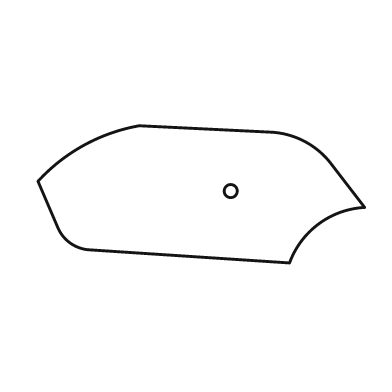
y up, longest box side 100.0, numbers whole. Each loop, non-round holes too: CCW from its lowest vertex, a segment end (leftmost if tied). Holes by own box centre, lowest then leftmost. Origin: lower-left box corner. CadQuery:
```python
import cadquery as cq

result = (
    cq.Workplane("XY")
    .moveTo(77.0, 0.0)
    .threePointArc((86.0, 12.0), (100.0, 17.0))
    .lineTo(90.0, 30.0)
    .threePointArc((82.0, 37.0), (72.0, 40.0))
    .lineTo(31.0, 42.0)
    .threePointArc((14.0, 36.0), (0.0, 25.0))
    .lineTo(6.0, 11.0)
    .threePointArc((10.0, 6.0), (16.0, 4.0))
    .close()
    .moveTo(59.0, 22.0)
    .circle(2.0)
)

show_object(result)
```